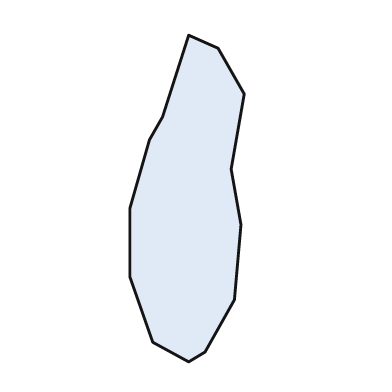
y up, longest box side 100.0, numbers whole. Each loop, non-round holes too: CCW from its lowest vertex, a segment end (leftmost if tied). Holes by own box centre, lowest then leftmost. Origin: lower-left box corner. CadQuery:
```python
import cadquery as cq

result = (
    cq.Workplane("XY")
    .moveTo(18.0, 0.0)
    .lineTo(23.0, 3.0)
    .lineTo(32.0, 19.0)
    .lineTo(34.0, 42.0)
    .lineTo(31.0, 59.0)
    .lineTo(35.0, 82.0)
    .lineTo(27.0, 96.0)
    .lineTo(18.0, 100.0)
    .lineTo(10.0, 75.0)
    .lineTo(6.0, 68.0)
    .lineTo(0.0, 47.0)
    .lineTo(0.0, 26.0)
    .lineTo(7.0, 6.0)
    .close()
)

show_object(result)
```